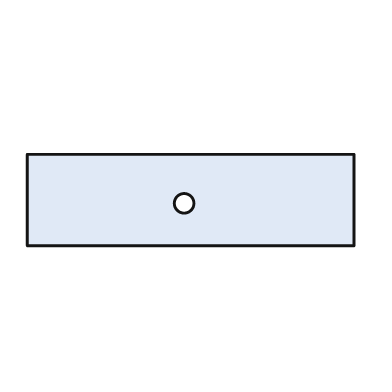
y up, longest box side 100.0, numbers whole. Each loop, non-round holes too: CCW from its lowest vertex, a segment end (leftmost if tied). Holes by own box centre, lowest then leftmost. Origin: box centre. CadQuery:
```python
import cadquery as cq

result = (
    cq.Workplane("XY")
    .moveTo(-50.0, -14.0)
    .lineTo(50.0, -14.0)
    .lineTo(50.0, 14.0)
    .lineTo(-50.0, 14.0)
    .close()
    .moveTo(-2.0, -1.0)
    .circle(3.0)
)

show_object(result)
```